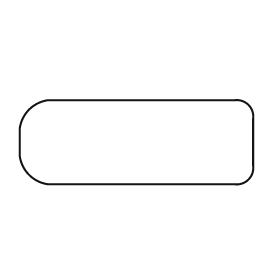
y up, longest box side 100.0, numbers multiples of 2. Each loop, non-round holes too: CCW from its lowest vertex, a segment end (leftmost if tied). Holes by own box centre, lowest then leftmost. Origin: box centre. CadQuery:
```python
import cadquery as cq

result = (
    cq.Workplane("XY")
    .moveTo(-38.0, -18.0)
    .lineTo(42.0, -18.0)
    .threePointArc((48.0, -16.0), (50.0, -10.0))
    .lineTo(50.0, 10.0)
    .threePointArc((48.0, 16.0), (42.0, 18.0))
    .lineTo(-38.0, 18.0)
    .threePointArc((-46.0, 14.0), (-50.0, 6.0))
    .lineTo(-50.0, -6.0)
    .threePointArc((-46.0, -14.0), (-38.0, -18.0))
    .close()
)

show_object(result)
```